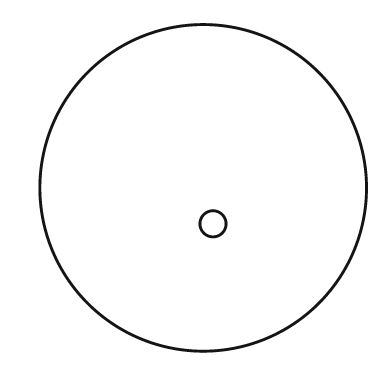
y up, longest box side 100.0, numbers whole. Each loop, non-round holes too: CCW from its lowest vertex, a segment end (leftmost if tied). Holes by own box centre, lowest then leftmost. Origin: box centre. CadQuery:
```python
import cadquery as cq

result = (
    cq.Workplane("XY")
    .moveTo(0.0, 0.0)
    .circle(50.0)
    .moveTo(3.0, -11.0)
    .circle(4.0)
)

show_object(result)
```